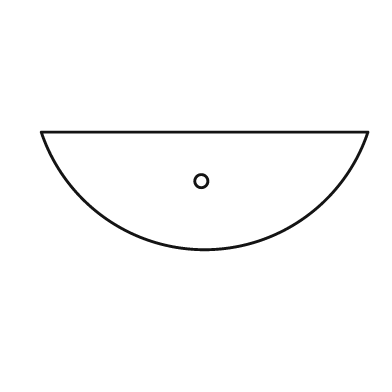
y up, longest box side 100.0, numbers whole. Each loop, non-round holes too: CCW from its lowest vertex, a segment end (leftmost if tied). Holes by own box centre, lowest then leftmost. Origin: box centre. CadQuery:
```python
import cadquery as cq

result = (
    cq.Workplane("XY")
    .moveTo(-50.0, 18.0)
    .threePointArc((0.0, -18.0), (50.0, 18.0))
    .close()
    .moveTo(-1.0, 3.0)
    .circle(2.0)
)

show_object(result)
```